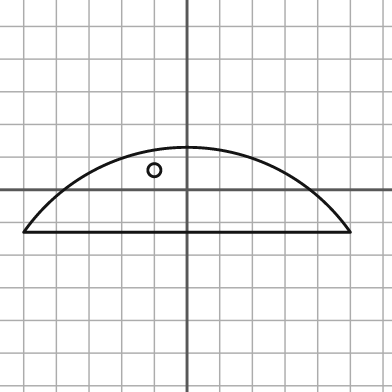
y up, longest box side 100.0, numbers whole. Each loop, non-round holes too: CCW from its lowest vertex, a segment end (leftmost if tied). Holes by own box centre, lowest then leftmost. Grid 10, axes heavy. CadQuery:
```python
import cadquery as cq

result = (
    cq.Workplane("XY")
    .moveTo(-50.0, -13.0)
    .lineTo(50.0, -13.0)
    .threePointArc((0.0, 13.0), (-50.0, -13.0))
    .close()
    .moveTo(-10.0, 6.0)
    .circle(2.0)
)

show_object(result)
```